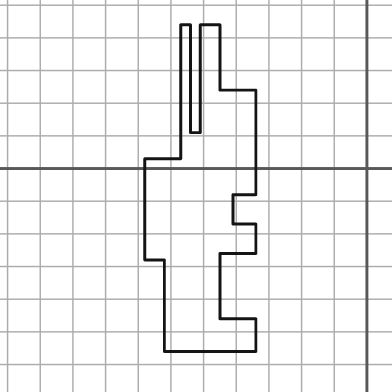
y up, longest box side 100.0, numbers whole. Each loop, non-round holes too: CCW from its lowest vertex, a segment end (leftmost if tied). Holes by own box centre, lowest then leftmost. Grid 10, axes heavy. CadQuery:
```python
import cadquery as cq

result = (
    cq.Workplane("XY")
    .moveTo(-62.0, -56.0)
    .lineTo(-34.0, -56.0)
    .lineTo(-34.0, -46.0)
    .lineTo(-45.0, -46.0)
    .lineTo(-45.0, -26.0)
    .lineTo(-34.0, -26.0)
    .lineTo(-34.0, -17.0)
    .lineTo(-41.0, -17.0)
    .lineTo(-41.0, -8.0)
    .lineTo(-34.0, -8.0)
    .lineTo(-34.0, 24.0)
    .lineTo(-45.0, 24.0)
    .lineTo(-45.0, 44.0)
    .lineTo(-51.0, 44.0)
    .lineTo(-51.0, 11.0)
    .lineTo(-54.0, 11.0)
    .lineTo(-54.0, 44.0)
    .lineTo(-57.0, 44.0)
    .lineTo(-57.0, 3.0)
    .lineTo(-68.0, 3.0)
    .lineTo(-68.0, -28.0)
    .lineTo(-62.0, -28.0)
    .close()
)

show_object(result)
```